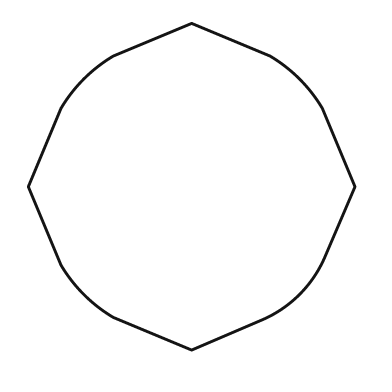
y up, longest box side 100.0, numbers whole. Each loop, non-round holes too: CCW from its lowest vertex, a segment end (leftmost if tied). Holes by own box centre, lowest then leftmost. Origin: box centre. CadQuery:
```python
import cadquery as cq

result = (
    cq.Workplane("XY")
    .moveTo(0.0, -50.0)
    .lineTo(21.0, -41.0)
    .threePointArc((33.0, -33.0), (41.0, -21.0))
    .lineTo(50.0, 0.0)
    .lineTo(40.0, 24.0)
    .threePointArc((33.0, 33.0), (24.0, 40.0))
    .lineTo(0.0, 50.0)
    .lineTo(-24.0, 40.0)
    .threePointArc((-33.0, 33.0), (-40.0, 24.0))
    .lineTo(-50.0, 0.0)
    .lineTo(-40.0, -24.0)
    .threePointArc((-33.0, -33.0), (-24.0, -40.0))
    .close()
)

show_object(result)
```